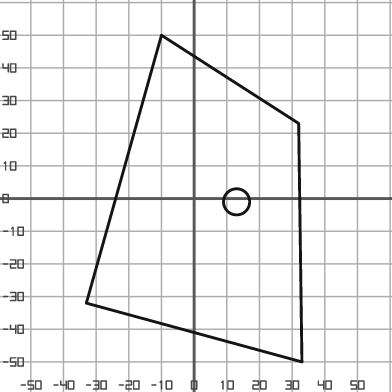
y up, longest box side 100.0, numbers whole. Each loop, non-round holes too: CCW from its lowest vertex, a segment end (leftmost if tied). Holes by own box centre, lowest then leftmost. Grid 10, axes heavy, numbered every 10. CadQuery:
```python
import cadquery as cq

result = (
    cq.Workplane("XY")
    .moveTo(33.0, -50.0)
    .lineTo(32.0, 23.0)
    .lineTo(-10.0, 50.0)
    .lineTo(-33.0, -32.0)
    .close()
    .moveTo(13.0, -1.0)
    .circle(4.0)
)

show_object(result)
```